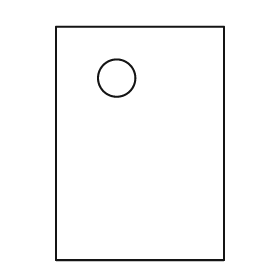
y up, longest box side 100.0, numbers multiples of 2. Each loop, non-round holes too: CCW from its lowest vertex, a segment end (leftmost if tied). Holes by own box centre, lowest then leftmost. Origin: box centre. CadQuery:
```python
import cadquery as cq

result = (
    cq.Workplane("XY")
    .moveTo(-36.0, -50.0)
    .lineTo(36.0, -50.0)
    .lineTo(36.0, 50.0)
    .lineTo(-36.0, 50.0)
    .close()
    .moveTo(-10.0, 28.0)
    .circle(8.0)
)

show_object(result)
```